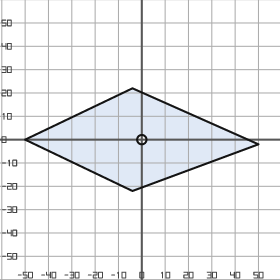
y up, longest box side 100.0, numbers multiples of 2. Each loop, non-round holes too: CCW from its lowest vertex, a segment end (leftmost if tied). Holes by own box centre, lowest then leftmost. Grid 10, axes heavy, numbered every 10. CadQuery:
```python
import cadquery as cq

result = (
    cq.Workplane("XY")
    .moveTo(-4.0, -22.0)
    .lineTo(50.0, -2.0)
    .lineTo(-4.0, 22.0)
    .lineTo(-50.0, 0.0)
    .close()
    .moveTo(0.0, 0.0)
    .circle(2.0)
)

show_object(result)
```